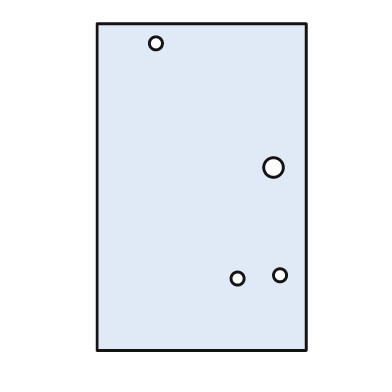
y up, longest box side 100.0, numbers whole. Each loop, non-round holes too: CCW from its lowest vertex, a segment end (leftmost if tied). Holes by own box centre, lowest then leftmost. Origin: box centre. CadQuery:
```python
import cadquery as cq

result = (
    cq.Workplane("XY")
    .moveTo(-32.0, -50.0)
    .lineTo(32.0, -50.0)
    .lineTo(32.0, 50.0)
    .lineTo(-32.0, 50.0)
    .close()
    .moveTo(11.0, -28.0)
    .circle(2.0)
    .moveTo(24.0, -27.0)
    .circle(2.0)
    .moveTo(22.0, 6.0)
    .circle(3.0)
    .moveTo(-14.0, 44.0)
    .circle(2.0)
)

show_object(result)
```